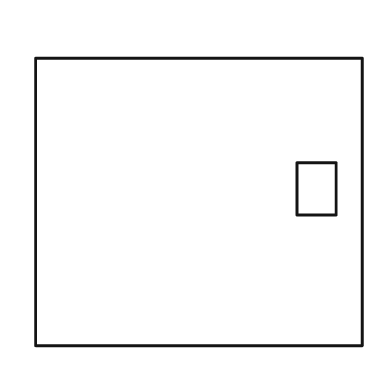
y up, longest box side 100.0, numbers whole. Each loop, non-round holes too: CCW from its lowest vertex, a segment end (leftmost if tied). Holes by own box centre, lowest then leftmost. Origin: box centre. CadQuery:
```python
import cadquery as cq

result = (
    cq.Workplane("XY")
    .moveTo(-50.0, -44.0)
    .lineTo(50.0, -44.0)
    .lineTo(50.0, 44.0)
    .lineTo(-50.0, 44.0)
    .close()
    .moveTo(30.0, -4.0)
    .lineTo(42.0, -4.0)
    .lineTo(42.0, 12.0)
    .lineTo(30.0, 12.0)
    .close()
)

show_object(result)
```